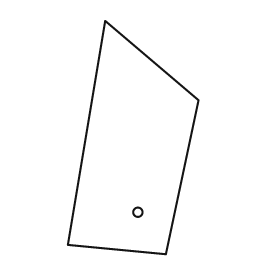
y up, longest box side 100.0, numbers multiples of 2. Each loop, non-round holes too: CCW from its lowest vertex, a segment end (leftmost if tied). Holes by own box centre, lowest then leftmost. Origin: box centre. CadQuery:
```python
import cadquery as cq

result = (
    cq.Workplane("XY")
    .moveTo(14.0, -50.0)
    .lineTo(28.0, 16.0)
    .lineTo(-12.0, 50.0)
    .lineTo(-28.0, -46.0)
    .close()
    .moveTo(2.0, -32.0)
    .circle(2.0)
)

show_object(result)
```